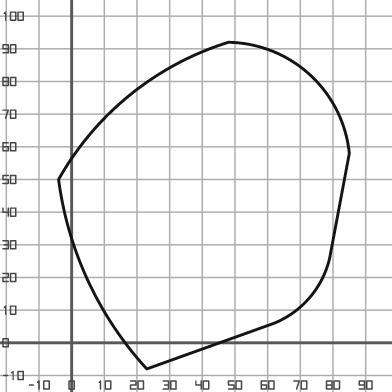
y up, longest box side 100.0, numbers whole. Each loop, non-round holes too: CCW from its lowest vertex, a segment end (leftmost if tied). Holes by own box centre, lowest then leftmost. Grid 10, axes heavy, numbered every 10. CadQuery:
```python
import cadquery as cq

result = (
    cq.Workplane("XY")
    .moveTo(23.0, -8.0)
    .lineTo(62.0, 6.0)
    .threePointArc((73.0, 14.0), (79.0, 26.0))
    .lineTo(85.0, 58.0)
    .threePointArc((73.0, 82.0), (48.0, 92.0))
    .threePointArc((18.0, 76.0), (-4.0, 50.0))
    .threePointArc((5.0, 19.0), (23.0, -8.0))
    .close()
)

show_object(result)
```